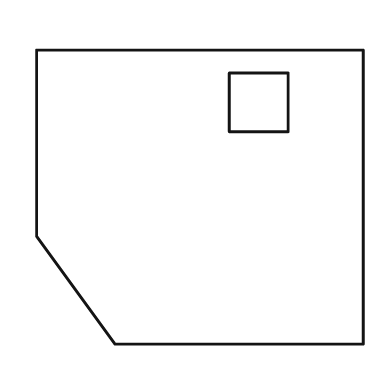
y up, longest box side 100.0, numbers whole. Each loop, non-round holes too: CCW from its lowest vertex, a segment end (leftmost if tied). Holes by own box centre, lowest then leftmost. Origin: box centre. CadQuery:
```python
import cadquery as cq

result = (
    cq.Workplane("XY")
    .moveTo(-26.0, -45.0)
    .lineTo(50.0, -45.0)
    .lineTo(50.0, 45.0)
    .lineTo(-50.0, 45.0)
    .lineTo(-50.0, -12.0)
    .close()
    .moveTo(9.0, 20.0)
    .lineTo(27.0, 20.0)
    .lineTo(27.0, 38.0)
    .lineTo(9.0, 38.0)
    .close()
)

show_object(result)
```